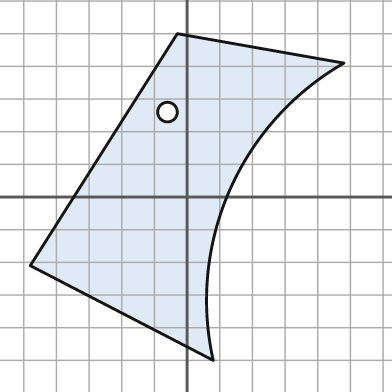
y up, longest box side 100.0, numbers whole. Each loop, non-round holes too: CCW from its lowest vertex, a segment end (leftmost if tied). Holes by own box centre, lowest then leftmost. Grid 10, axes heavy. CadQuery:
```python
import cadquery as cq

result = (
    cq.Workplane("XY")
    .moveTo(8.0, -50.0)
    .threePointArc((13.0, 2.0), (48.0, 41.0))
    .lineTo(-3.0, 50.0)
    .lineTo(-48.0, -21.0)
    .close()
    .moveTo(-6.0, 26.0)
    .circle(3.0)
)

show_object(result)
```